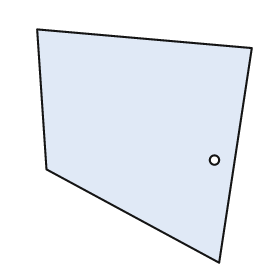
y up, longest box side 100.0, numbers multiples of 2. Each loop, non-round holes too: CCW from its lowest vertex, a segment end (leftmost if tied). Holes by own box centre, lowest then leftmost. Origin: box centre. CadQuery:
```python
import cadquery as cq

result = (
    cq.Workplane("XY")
    .moveTo(32.0, -50.0)
    .lineTo(46.0, 42.0)
    .lineTo(-46.0, 50.0)
    .lineTo(-42.0, -10.0)
    .close()
    .moveTo(30.0, -6.0)
    .circle(2.0)
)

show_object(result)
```